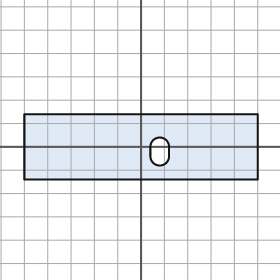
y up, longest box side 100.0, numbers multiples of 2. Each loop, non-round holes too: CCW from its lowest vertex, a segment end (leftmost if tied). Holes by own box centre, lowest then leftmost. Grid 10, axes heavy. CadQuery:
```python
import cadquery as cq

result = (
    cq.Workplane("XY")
    .moveTo(-50.0, -14.0)
    .lineTo(50.0, -14.0)
    .lineTo(50.0, 14.0)
    .lineTo(-50.0, 14.0)
    .close()
    .moveTo(4.0, -4.0)
    .threePointArc((8.0, -8.0), (12.0, -4.0))
    .lineTo(12.0, 0.0)
    .threePointArc((8.0, 4.0), (4.0, 0.0))
    .close()
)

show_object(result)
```